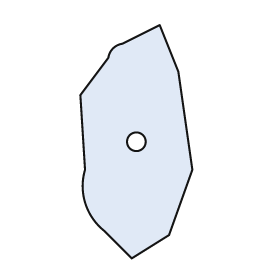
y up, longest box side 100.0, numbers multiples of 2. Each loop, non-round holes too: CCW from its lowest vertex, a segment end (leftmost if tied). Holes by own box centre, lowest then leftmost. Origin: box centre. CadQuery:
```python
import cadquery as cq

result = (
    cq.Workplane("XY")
    .moveTo(-2.0, -50.0)
    .lineTo(14.0, -40.0)
    .lineTo(24.0, -12.0)
    .lineTo(18.0, 30.0)
    .lineTo(10.0, 50.0)
    .lineTo(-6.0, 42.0)
    .threePointArc((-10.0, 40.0), (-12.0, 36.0))
    .lineTo(-24.0, 20.0)
    .lineTo(-22.0, -12.0)
    .threePointArc((-22.0, -26.0), (-14.0, -38.0))
    .close()
    .moveTo(0.0, 0.0)
    .circle(4.0)
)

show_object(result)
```